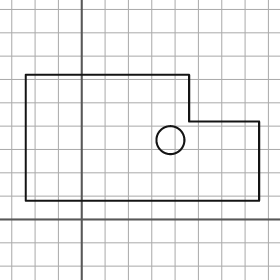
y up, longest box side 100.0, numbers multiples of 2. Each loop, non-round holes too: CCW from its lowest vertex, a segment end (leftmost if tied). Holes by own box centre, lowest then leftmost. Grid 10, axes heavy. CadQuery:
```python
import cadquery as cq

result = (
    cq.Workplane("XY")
    .moveTo(-24.0, 8.0)
    .lineTo(76.0, 8.0)
    .lineTo(76.0, 42.0)
    .lineTo(46.0, 42.0)
    .lineTo(46.0, 62.0)
    .lineTo(-24.0, 62.0)
    .close()
    .moveTo(38.0, 34.0)
    .circle(6.0)
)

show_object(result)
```